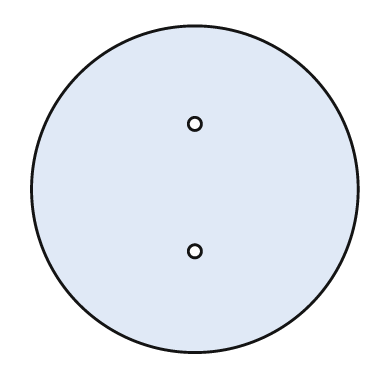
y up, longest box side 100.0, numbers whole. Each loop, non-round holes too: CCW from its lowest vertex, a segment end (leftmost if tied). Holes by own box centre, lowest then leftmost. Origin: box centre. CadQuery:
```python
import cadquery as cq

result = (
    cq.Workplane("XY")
    .moveTo(0.0, 0.0)
    .circle(50.0)
    .moveTo(0.0, -19.0)
    .circle(2.0)
    .moveTo(0.0, 20.0)
    .circle(2.0)
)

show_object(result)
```